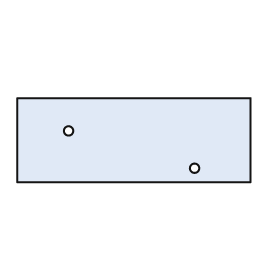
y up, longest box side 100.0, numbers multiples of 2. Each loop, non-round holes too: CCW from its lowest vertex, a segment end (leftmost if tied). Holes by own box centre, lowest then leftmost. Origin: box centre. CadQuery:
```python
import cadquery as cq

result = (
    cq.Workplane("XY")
    .moveTo(-50.0, -18.0)
    .lineTo(50.0, -18.0)
    .lineTo(50.0, 18.0)
    .lineTo(-50.0, 18.0)
    .close()
    .moveTo(26.0, -12.0)
    .circle(2.0)
    .moveTo(-28.0, 4.0)
    .circle(2.0)
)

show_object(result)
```